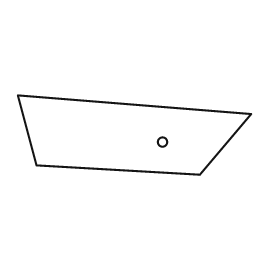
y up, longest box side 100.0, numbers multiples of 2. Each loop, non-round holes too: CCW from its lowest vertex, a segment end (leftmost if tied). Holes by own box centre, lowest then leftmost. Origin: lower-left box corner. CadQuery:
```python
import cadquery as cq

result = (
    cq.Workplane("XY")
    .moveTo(78.0, 0.0)
    .lineTo(100.0, 26.0)
    .lineTo(0.0, 34.0)
    .lineTo(8.0, 4.0)
    .close()
    .moveTo(62.0, 14.0)
    .circle(2.0)
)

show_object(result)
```